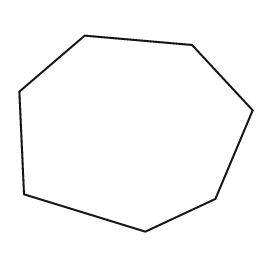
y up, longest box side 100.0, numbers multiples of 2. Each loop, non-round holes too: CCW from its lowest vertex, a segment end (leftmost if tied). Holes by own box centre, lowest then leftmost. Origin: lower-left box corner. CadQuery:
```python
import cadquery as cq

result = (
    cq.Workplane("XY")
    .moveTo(54.0, 0.0)
    .lineTo(84.0, 14.0)
    .lineTo(100.0, 52.0)
    .lineTo(74.0, 80.0)
    .lineTo(28.0, 84.0)
    .lineTo(0.0, 60.0)
    .lineTo(2.0, 16.0)
    .close()
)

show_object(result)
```